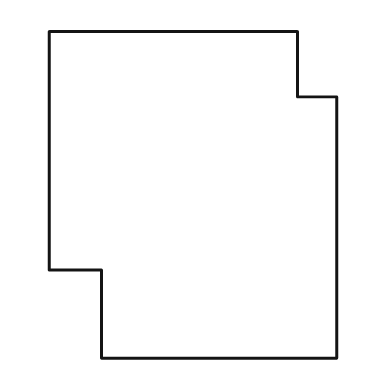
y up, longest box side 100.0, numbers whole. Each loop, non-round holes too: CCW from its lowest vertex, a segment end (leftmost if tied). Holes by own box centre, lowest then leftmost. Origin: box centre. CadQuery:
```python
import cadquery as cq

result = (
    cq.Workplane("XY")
    .moveTo(-28.0, -50.0)
    .lineTo(44.0, -50.0)
    .lineTo(44.0, 30.0)
    .lineTo(32.0, 30.0)
    .lineTo(32.0, 50.0)
    .lineTo(-44.0, 50.0)
    .lineTo(-44.0, -23.0)
    .lineTo(-28.0, -23.0)
    .close()
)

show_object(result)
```